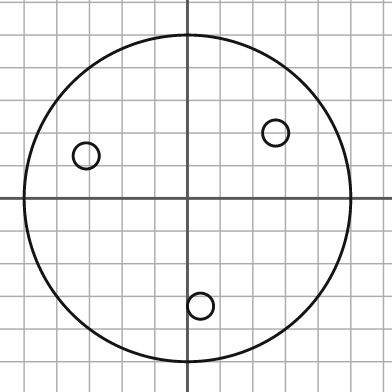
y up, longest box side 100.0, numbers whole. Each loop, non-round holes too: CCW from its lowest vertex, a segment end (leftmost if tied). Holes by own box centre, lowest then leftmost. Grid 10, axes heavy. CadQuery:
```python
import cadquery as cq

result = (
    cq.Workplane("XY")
    .moveTo(0.0, 0.0)
    .circle(50.0)
    .moveTo(4.0, -33.0)
    .circle(4.0)
    .moveTo(-31.0, 13.0)
    .circle(4.0)
    .moveTo(27.0, 20.0)
    .circle(4.0)
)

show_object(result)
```